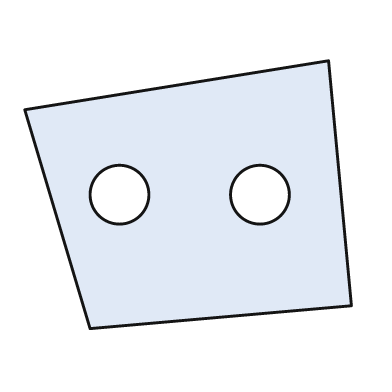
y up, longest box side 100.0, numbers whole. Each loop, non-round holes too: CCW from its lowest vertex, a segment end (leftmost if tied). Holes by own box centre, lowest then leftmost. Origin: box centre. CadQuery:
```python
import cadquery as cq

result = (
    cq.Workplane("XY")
    .moveTo(-30.0, -41.0)
    .lineTo(50.0, -34.0)
    .lineTo(43.0, 41.0)
    .lineTo(-50.0, 26.0)
    .close()
    .moveTo(-21.0, 0.0)
    .circle(9.0)
    .moveTo(22.0, 0.0)
    .circle(9.0)
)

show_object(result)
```